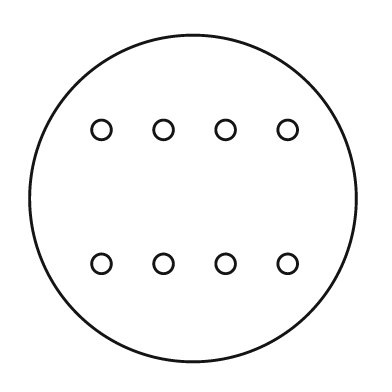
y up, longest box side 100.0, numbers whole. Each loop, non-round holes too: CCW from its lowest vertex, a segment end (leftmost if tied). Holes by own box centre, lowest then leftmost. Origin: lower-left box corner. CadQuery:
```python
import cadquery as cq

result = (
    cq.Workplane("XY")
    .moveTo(50.0, 50.0)
    .circle(50.0)
    .moveTo(22.0, 30.0)
    .circle(3.0)
    .moveTo(41.0, 30.0)
    .circle(3.0)
    .moveTo(60.0, 30.0)
    .circle(3.0)
    .moveTo(79.0, 30.0)
    .circle(3.0)
    .moveTo(22.0, 71.0)
    .circle(3.0)
    .moveTo(41.0, 71.0)
    .circle(3.0)
    .moveTo(60.0, 71.0)
    .circle(3.0)
    .moveTo(79.0, 71.0)
    .circle(3.0)
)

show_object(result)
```